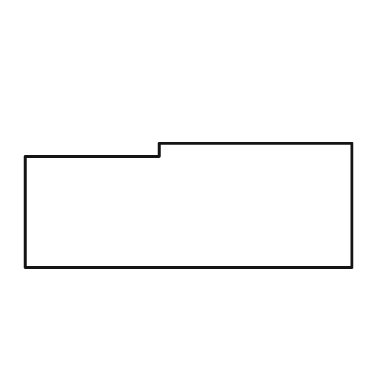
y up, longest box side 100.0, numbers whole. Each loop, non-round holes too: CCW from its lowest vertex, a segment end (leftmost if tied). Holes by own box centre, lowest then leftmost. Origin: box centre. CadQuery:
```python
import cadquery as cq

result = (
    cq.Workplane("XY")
    .moveTo(-50.0, -19.0)
    .lineTo(50.0, -19.0)
    .lineTo(50.0, 19.0)
    .lineTo(-9.0, 19.0)
    .lineTo(-9.0, 15.0)
    .lineTo(-50.0, 15.0)
    .close()
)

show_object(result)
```